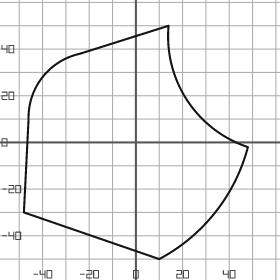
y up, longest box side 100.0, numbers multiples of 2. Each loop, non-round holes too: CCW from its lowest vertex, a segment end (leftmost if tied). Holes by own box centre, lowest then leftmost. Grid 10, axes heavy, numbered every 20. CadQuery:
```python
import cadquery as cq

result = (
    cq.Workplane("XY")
    .moveTo(10.0, -50.0)
    .threePointArc((34.0, -30.0), (48.0, -2.0))
    .threePointArc((22.0, 18.0), (14.0, 50.0))
    .lineTo(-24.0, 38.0)
    .threePointArc((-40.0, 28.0), (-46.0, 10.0))
    .lineTo(-48.0, -30.0)
    .close()
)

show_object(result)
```